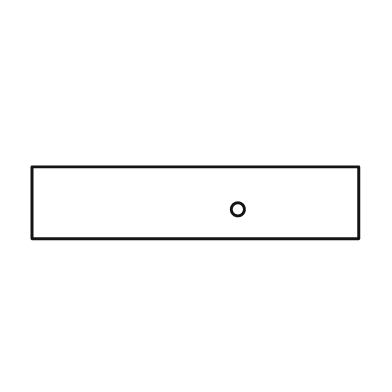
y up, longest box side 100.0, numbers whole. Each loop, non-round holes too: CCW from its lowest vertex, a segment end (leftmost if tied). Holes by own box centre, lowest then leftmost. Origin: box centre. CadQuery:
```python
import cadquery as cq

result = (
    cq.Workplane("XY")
    .moveTo(-50.0, -11.0)
    .lineTo(50.0, -11.0)
    .lineTo(50.0, 11.0)
    .lineTo(-50.0, 11.0)
    .close()
    .moveTo(13.0, -2.0)
    .circle(2.0)
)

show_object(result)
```